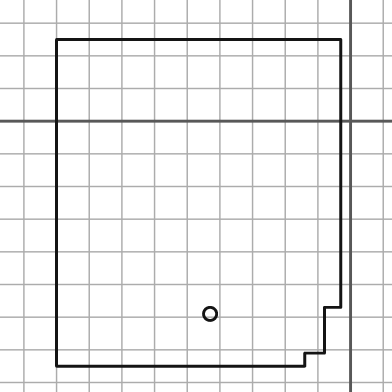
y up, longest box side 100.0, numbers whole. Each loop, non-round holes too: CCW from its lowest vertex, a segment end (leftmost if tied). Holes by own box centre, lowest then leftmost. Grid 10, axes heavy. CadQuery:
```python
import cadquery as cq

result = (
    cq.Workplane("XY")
    .moveTo(-90.0, -75.0)
    .lineTo(-14.0, -75.0)
    .lineTo(-14.0, -71.0)
    .lineTo(-8.0, -71.0)
    .lineTo(-8.0, -57.0)
    .lineTo(-3.0, -57.0)
    .lineTo(-3.0, 25.0)
    .lineTo(-90.0, 25.0)
    .close()
    .moveTo(-43.0, -59.0)
    .circle(2.0)
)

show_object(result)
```